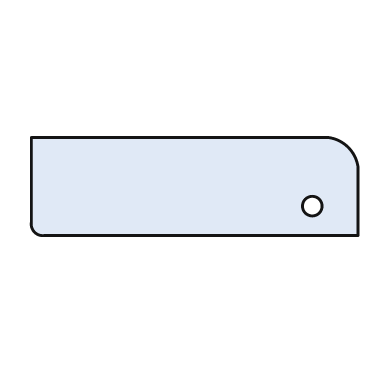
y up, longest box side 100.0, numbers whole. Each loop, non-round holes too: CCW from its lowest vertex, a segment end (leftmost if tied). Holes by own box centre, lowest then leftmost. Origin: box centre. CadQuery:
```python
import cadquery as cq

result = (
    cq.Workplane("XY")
    .moveTo(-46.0, -15.0)
    .lineTo(50.0, -15.0)
    .lineTo(50.0, 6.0)
    .threePointArc((47.0, 12.0), (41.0, 15.0))
    .lineTo(-50.0, 15.0)
    .lineTo(-50.0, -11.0)
    .threePointArc((-49.0, -14.0), (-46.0, -15.0))
    .close()
    .moveTo(36.0, -6.0)
    .circle(3.0)
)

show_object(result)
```